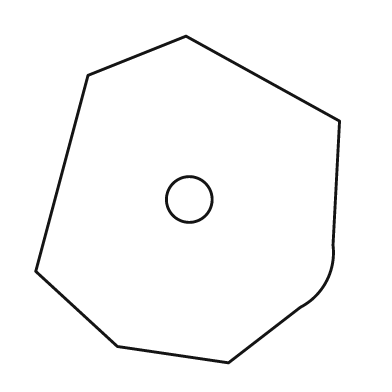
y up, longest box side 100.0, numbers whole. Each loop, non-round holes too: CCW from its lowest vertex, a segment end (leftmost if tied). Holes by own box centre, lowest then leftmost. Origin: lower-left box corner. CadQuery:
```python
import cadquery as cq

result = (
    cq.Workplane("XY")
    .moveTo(59.0, 0.0)
    .lineTo(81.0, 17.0)
    .threePointArc((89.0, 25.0), (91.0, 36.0))
    .lineTo(93.0, 74.0)
    .lineTo(46.0, 100.0)
    .lineTo(16.0, 88.0)
    .lineTo(0.0, 28.0)
    .lineTo(25.0, 5.0)
    .close()
    .moveTo(47.0, 50.0)
    .circle(7.0)
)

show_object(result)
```